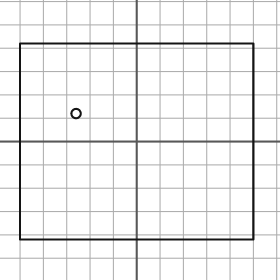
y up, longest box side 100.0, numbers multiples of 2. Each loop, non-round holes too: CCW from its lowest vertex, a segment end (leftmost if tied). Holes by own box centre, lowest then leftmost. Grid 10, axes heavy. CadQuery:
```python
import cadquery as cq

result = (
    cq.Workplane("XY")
    .moveTo(-50.0, -42.0)
    .lineTo(50.0, -42.0)
    .lineTo(50.0, 42.0)
    .lineTo(-50.0, 42.0)
    .close()
    .moveTo(-26.0, 12.0)
    .circle(2.0)
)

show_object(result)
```